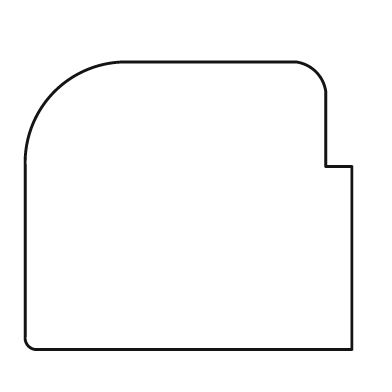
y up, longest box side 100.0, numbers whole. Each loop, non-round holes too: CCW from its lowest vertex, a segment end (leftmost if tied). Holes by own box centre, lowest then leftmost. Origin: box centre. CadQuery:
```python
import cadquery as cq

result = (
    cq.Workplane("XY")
    .moveTo(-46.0, -44.0)
    .lineTo(50.0, -44.0)
    .lineTo(50.0, 12.0)
    .lineTo(42.0, 12.0)
    .lineTo(42.0, 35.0)
    .threePointArc((39.0, 41.0), (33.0, 44.0))
    .lineTo(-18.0, 44.0)
    .threePointArc((-41.0, 35.0), (-50.0, 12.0))
    .lineTo(-50.0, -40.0)
    .threePointArc((-49.0, -43.0), (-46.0, -44.0))
    .close()
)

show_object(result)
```